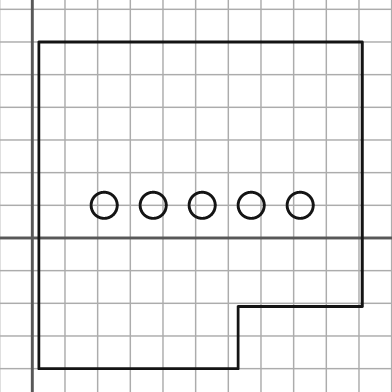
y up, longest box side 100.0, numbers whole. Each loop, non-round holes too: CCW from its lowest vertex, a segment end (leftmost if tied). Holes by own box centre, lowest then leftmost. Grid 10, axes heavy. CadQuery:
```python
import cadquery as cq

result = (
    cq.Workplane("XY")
    .moveTo(2.0, -40.0)
    .lineTo(63.0, -40.0)
    .lineTo(63.0, -21.0)
    .lineTo(101.0, -21.0)
    .lineTo(101.0, 60.0)
    .lineTo(2.0, 60.0)
    .close()
    .moveTo(22.0, 10.0)
    .circle(4.0)
    .moveTo(37.0, 10.0)
    .circle(4.0)
    .moveTo(52.0, 10.0)
    .circle(4.0)
    .moveTo(67.0, 10.0)
    .circle(4.0)
    .moveTo(82.0, 10.0)
    .circle(4.0)
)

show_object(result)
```